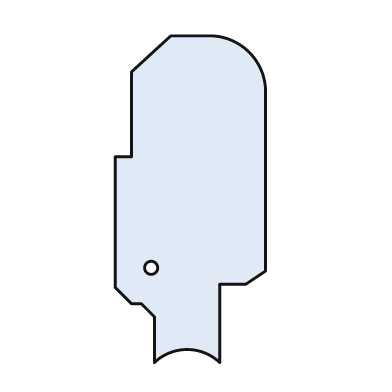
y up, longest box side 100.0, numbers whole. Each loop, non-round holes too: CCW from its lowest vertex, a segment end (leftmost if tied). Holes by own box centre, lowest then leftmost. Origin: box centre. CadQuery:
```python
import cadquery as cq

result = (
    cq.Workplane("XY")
    .moveTo(-11.0, -50.0)
    .threePointArc((-1.0, -46.0), (9.0, -50.0))
    .lineTo(9.0, -26.0)
    .lineTo(17.0, -26.0)
    .lineTo(23.0, -22.0)
    .lineTo(23.0, 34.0)
    .threePointArc((18.0, 45.0), (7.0, 50.0))
    .lineTo(-6.0, 50.0)
    .lineTo(-18.0, 39.0)
    .lineTo(-18.0, 13.0)
    .lineTo(-23.0, 13.0)
    .lineTo(-23.0, -27.0)
    .lineTo(-18.0, -32.0)
    .lineTo(-15.0, -32.0)
    .lineTo(-11.0, -36.0)
    .close()
    .moveTo(-12.0, -21.0)
    .circle(2.0)
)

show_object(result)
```